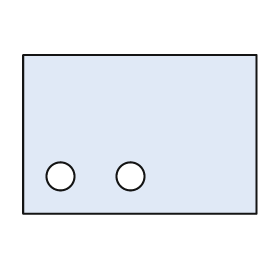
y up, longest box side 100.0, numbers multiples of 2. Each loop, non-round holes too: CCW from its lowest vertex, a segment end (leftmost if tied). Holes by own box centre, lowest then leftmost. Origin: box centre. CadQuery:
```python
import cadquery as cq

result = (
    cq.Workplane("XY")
    .moveTo(-50.0, -34.0)
    .lineTo(50.0, -34.0)
    .lineTo(50.0, 34.0)
    .lineTo(-50.0, 34.0)
    .close()
    .moveTo(-34.0, -18.0)
    .circle(6.0)
    .moveTo(-4.0, -18.0)
    .circle(6.0)
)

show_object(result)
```